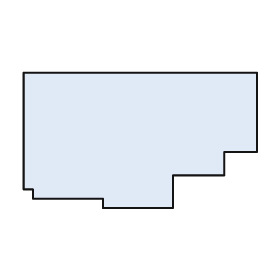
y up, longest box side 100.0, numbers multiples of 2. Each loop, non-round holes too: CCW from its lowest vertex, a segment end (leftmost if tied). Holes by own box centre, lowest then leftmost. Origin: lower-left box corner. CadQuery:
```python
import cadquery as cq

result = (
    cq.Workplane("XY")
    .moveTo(34.0, 0.0)
    .lineTo(64.0, 0.0)
    .lineTo(64.0, 14.0)
    .lineTo(86.0, 14.0)
    .lineTo(86.0, 24.0)
    .lineTo(100.0, 24.0)
    .lineTo(100.0, 58.0)
    .lineTo(0.0, 58.0)
    .lineTo(0.0, 8.0)
    .lineTo(4.0, 8.0)
    .lineTo(4.0, 4.0)
    .lineTo(34.0, 4.0)
    .close()
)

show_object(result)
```